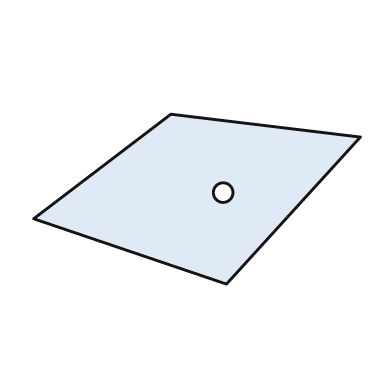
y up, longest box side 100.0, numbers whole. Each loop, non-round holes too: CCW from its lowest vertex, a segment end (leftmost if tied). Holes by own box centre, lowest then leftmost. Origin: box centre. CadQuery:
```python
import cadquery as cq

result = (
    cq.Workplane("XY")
    .moveTo(9.0, -26.0)
    .lineTo(50.0, 19.0)
    .lineTo(-8.0, 26.0)
    .lineTo(-50.0, -6.0)
    .close()
    .moveTo(8.0, 2.0)
    .circle(3.0)
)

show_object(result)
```